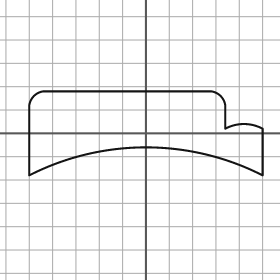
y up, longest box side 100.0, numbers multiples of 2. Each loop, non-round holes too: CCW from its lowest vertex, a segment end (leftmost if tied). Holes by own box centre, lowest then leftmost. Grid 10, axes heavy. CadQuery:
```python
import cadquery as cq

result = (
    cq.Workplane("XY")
    .moveTo(-50.0, -18.0)
    .threePointArc((0.0, -6.0), (50.0, -18.0))
    .lineTo(50.0, 2.0)
    .threePointArc((42.0, 4.0), (34.0, 2.0))
    .lineTo(34.0, 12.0)
    .threePointArc((32.0, 16.0), (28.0, 18.0))
    .lineTo(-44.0, 18.0)
    .threePointArc((-48.0, 16.0), (-50.0, 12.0))
    .close()
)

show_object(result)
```